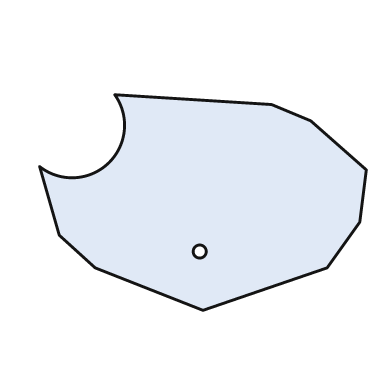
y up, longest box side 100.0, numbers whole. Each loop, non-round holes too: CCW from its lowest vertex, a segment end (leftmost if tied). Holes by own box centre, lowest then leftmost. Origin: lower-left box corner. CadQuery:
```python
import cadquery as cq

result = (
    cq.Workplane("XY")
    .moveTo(50.0, 0.0)
    .lineTo(88.0, 13.0)
    .lineTo(98.0, 27.0)
    .lineTo(100.0, 43.0)
    .lineTo(83.0, 58.0)
    .lineTo(71.0, 63.0)
    .lineTo(23.0, 66.0)
    .threePointArc((21.0, 45.0), (0.0, 44.0))
    .lineTo(6.0, 23.0)
    .lineTo(17.0, 13.0)
    .close()
    .moveTo(49.0, 18.0)
    .circle(2.0)
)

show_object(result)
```